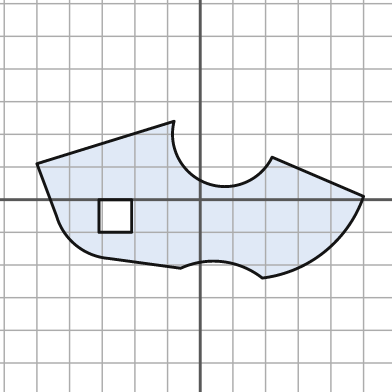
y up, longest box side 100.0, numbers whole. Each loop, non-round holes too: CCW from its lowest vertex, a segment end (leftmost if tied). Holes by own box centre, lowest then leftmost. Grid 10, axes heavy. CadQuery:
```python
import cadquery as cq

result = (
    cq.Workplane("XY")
    .moveTo(19.0, -24.0)
    .threePointArc((38.0, -16.0), (50.0, 1.0))
    .lineTo(22.0, 13.0)
    .threePointArc((2.0, 5.0), (-8.0, 24.0))
    .lineTo(-50.0, 11.0)
    .lineTo(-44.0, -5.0)
    .threePointArc((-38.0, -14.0), (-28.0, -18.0))
    .lineTo(-6.0, -21.0)
    .threePointArc((7.0, -19.0), (19.0, -24.0))
    .close()
    .moveTo(-31.0, -10.0)
    .lineTo(-21.0, -10.0)
    .lineTo(-21.0, 0.0)
    .lineTo(-31.0, 0.0)
    .close()
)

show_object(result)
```